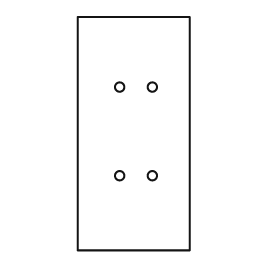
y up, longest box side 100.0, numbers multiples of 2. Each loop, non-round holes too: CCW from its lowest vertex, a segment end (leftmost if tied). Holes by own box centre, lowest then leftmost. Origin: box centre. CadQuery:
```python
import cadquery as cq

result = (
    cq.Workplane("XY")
    .moveTo(-24.0, -50.0)
    .lineTo(24.0, -50.0)
    .lineTo(24.0, 50.0)
    .lineTo(-24.0, 50.0)
    .close()
    .moveTo(-6.0, -18.0)
    .circle(2.0)
    .moveTo(8.0, -18.0)
    .circle(2.0)
    .moveTo(-6.0, 20.0)
    .circle(2.0)
    .moveTo(8.0, 20.0)
    .circle(2.0)
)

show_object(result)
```